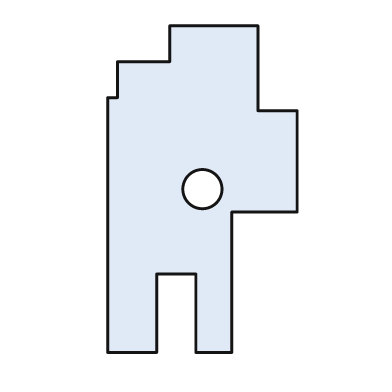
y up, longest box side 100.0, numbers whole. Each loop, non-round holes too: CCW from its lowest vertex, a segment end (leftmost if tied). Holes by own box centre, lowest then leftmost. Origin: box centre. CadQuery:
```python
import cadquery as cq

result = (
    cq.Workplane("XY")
    .moveTo(-29.0, -50.0)
    .lineTo(-14.0, -50.0)
    .lineTo(-14.0, -26.0)
    .lineTo(-2.0, -26.0)
    .lineTo(-2.0, -50.0)
    .lineTo(9.0, -50.0)
    .lineTo(9.0, -7.0)
    .lineTo(29.0, -7.0)
    .lineTo(29.0, 24.0)
    .lineTo(17.0, 24.0)
    .lineTo(17.0, 50.0)
    .lineTo(-10.0, 50.0)
    .lineTo(-10.0, 39.0)
    .lineTo(-26.0, 39.0)
    .lineTo(-26.0, 28.0)
    .lineTo(-29.0, 28.0)
    .close()
    .moveTo(0.0, 0.0)
    .circle(6.0)
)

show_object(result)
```